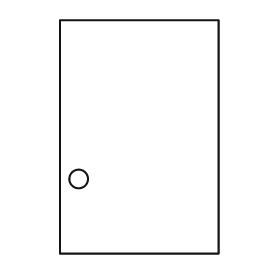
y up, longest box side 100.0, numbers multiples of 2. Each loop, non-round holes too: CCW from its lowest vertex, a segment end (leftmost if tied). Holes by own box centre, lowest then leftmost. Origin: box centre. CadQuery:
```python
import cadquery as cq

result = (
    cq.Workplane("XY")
    .moveTo(-34.0, -50.0)
    .lineTo(34.0, -50.0)
    .lineTo(34.0, 50.0)
    .lineTo(-34.0, 50.0)
    .close()
    .moveTo(-26.0, -18.0)
    .circle(4.0)
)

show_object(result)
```